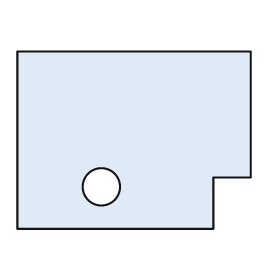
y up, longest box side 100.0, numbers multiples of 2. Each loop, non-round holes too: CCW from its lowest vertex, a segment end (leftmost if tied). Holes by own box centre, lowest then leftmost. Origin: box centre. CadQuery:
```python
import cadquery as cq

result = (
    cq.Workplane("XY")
    .moveTo(-50.0, -38.0)
    .lineTo(34.0, -38.0)
    .lineTo(34.0, -16.0)
    .lineTo(50.0, -16.0)
    .lineTo(50.0, 38.0)
    .lineTo(-50.0, 38.0)
    .close()
    .moveTo(-14.0, -20.0)
    .circle(8.0)
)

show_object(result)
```